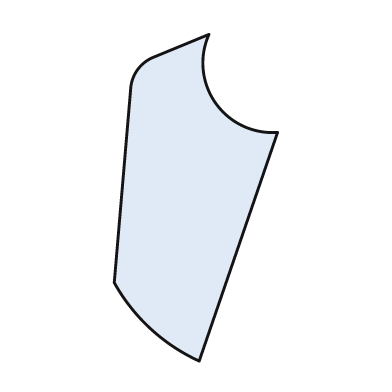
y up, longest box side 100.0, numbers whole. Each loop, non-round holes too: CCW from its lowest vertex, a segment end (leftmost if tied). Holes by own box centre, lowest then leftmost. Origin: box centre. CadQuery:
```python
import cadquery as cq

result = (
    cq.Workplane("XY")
    .moveTo(1.0, -50.0)
    .lineTo(25.0, 20.0)
    .threePointArc((6.0, 29.0), (4.0, 50.0))
    .lineTo(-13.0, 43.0)
    .threePointArc((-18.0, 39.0), (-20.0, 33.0))
    .lineTo(-25.0, -26.0)
    .threePointArc((-14.0, -40.0), (1.0, -50.0))
    .close()
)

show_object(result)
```